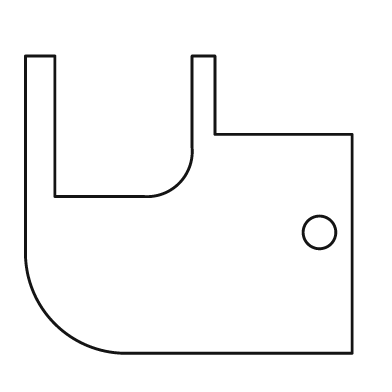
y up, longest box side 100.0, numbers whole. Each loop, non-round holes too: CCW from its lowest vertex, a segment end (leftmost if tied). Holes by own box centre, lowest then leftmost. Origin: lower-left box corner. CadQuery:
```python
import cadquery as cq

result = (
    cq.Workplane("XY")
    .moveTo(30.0, 0.0)
    .lineTo(100.0, 0.0)
    .lineTo(100.0, 67.0)
    .lineTo(58.0, 67.0)
    .lineTo(58.0, 91.0)
    .lineTo(51.0, 91.0)
    .lineTo(51.0, 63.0)
    .threePointArc((47.0, 52.0), (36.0, 48.0))
    .lineTo(9.0, 48.0)
    .lineTo(9.0, 91.0)
    .lineTo(0.0, 91.0)
    .lineTo(0.0, 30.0)
    .threePointArc((9.0, 9.0), (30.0, 0.0))
    .close()
    .moveTo(90.0, 37.0)
    .circle(5.0)
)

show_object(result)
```